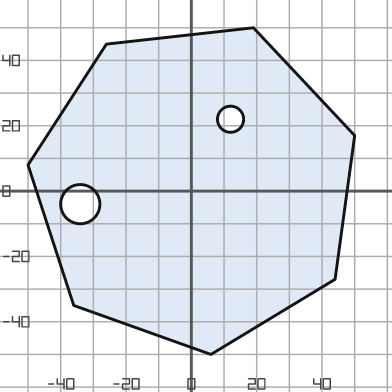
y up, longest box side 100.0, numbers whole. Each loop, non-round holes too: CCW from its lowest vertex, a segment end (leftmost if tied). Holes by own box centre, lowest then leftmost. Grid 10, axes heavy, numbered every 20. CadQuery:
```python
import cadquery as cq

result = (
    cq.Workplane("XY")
    .moveTo(6.0, -50.0)
    .lineTo(44.0, -27.0)
    .lineTo(50.0, 17.0)
    .lineTo(19.0, 50.0)
    .lineTo(-26.0, 45.0)
    .lineTo(-50.0, 8.0)
    .lineTo(-36.0, -35.0)
    .close()
    .moveTo(-34.0, -4.0)
    .circle(6.0)
    .moveTo(12.0, 22.0)
    .circle(4.0)
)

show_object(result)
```